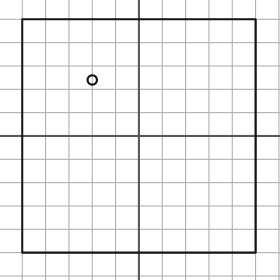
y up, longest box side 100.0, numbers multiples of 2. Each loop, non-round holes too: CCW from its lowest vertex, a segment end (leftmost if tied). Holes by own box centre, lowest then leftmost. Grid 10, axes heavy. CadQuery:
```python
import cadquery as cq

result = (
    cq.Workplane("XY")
    .moveTo(-50.0, -50.0)
    .lineTo(50.0, -50.0)
    .lineTo(50.0, 50.0)
    .lineTo(-50.0, 50.0)
    .close()
    .moveTo(-20.0, 24.0)
    .circle(2.0)
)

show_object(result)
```